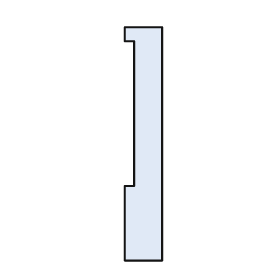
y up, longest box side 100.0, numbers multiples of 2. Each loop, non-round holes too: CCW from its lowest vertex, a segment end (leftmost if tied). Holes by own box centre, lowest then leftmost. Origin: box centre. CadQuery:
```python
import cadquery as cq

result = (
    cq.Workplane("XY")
    .moveTo(-8.0, -50.0)
    .lineTo(8.0, -50.0)
    .lineTo(8.0, 50.0)
    .lineTo(-8.0, 50.0)
    .lineTo(-8.0, 44.0)
    .lineTo(-4.0, 44.0)
    .lineTo(-4.0, -18.0)
    .lineTo(-8.0, -18.0)
    .close()
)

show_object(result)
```